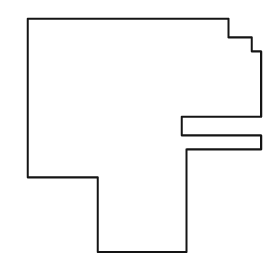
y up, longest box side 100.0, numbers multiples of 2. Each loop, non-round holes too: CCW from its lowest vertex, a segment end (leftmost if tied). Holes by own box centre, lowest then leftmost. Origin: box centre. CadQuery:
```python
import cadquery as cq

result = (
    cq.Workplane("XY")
    .moveTo(-20.0, -50.0)
    .lineTo(18.0, -50.0)
    .lineTo(18.0, -6.0)
    .lineTo(50.0, -6.0)
    .lineTo(50.0, 0.0)
    .lineTo(16.0, 0.0)
    .lineTo(16.0, 8.0)
    .lineTo(50.0, 8.0)
    .lineTo(50.0, 36.0)
    .lineTo(46.0, 36.0)
    .lineTo(46.0, 42.0)
    .lineTo(36.0, 42.0)
    .lineTo(36.0, 50.0)
    .lineTo(-50.0, 50.0)
    .lineTo(-50.0, -18.0)
    .lineTo(-20.0, -18.0)
    .close()
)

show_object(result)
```